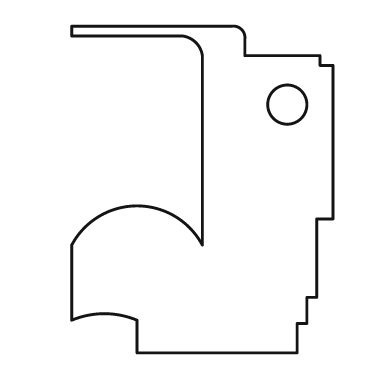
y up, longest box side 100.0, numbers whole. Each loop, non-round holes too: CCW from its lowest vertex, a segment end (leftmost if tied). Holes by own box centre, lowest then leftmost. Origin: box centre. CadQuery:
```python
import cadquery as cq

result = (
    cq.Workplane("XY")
    .moveTo(-20.0, -50.0)
    .lineTo(29.0, -50.0)
    .lineTo(29.0, -41.0)
    .lineTo(32.0, -41.0)
    .lineTo(32.0, -33.0)
    .lineTo(35.0, -33.0)
    .lineTo(35.0, -9.0)
    .lineTo(40.0, -9.0)
    .lineTo(40.0, 38.0)
    .lineTo(36.0, 38.0)
    .lineTo(36.0, 41.0)
    .lineTo(13.0, 41.0)
    .lineTo(13.0, 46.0)
    .threePointArc((12.0, 49.0), (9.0, 50.0))
    .lineTo(-40.0, 50.0)
    .lineTo(-40.0, 47.0)
    .lineTo(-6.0, 47.0)
    .threePointArc((-2.0, 45.0), (0.0, 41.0))
    .lineTo(0.0, -17.0)
    .threePointArc((-20.0, -5.0), (-40.0, -17.0))
    .lineTo(-40.0, -40.0)
    .threePointArc((-30.0, -38.0), (-20.0, -40.0))
    .close()
    .moveTo(26.0, 26.0)
    .circle(6.0)
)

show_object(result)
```